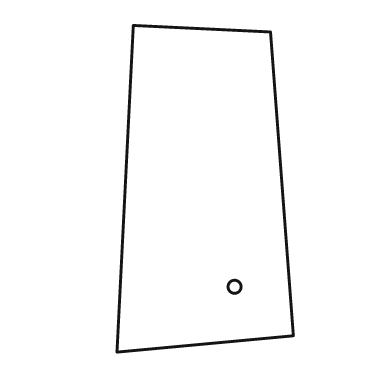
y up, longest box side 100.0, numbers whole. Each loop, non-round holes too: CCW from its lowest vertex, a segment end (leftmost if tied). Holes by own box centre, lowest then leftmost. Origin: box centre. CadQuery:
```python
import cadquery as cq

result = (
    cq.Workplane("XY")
    .moveTo(-27.0, -50.0)
    .lineTo(27.0, -45.0)
    .lineTo(20.0, 48.0)
    .lineTo(-22.0, 50.0)
    .close()
    .moveTo(9.0, -30.0)
    .circle(2.0)
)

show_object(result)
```